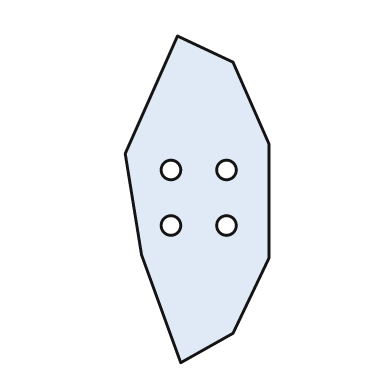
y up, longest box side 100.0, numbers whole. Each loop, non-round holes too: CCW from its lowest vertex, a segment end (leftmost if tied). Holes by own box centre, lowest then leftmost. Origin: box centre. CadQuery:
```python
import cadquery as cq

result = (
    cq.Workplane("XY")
    .moveTo(-5.0, -50.0)
    .lineTo(11.0, -41.0)
    .lineTo(22.0, -18.0)
    .lineTo(22.0, 17.0)
    .lineTo(11.0, 42.0)
    .lineTo(-6.0, 50.0)
    .lineTo(-22.0, 14.0)
    .lineTo(-17.0, -17.0)
    .close()
    .moveTo(-8.0, -8.0)
    .circle(3.0)
    .moveTo(9.0, -8.0)
    .circle(3.0)
    .moveTo(-8.0, 9.0)
    .circle(3.0)
    .moveTo(9.0, 9.0)
    .circle(3.0)
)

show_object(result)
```